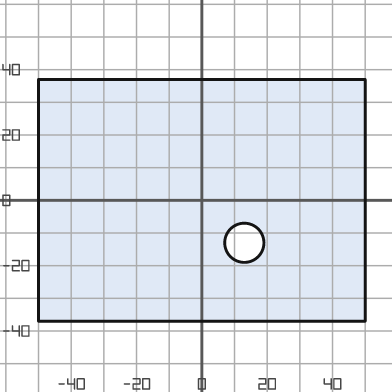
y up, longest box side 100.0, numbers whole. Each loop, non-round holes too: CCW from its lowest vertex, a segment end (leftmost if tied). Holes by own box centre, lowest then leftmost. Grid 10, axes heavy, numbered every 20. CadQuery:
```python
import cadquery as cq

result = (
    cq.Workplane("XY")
    .moveTo(-50.0, -37.0)
    .lineTo(50.0, -37.0)
    .lineTo(50.0, 37.0)
    .lineTo(-50.0, 37.0)
    .close()
    .moveTo(13.0, -13.0)
    .circle(6.0)
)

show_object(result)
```